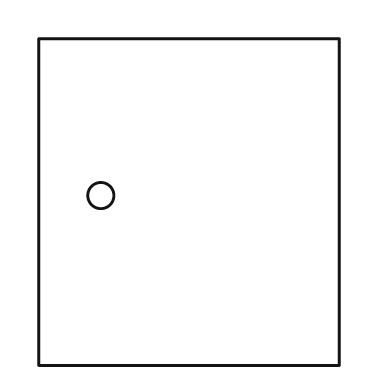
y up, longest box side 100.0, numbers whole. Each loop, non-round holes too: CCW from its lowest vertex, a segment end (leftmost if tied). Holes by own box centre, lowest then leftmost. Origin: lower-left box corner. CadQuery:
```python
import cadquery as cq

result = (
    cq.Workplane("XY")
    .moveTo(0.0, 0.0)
    .lineTo(92.0, 0.0)
    .lineTo(92.0, 100.0)
    .lineTo(0.0, 100.0)
    .close()
    .moveTo(19.0, 52.0)
    .circle(4.0)
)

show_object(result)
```